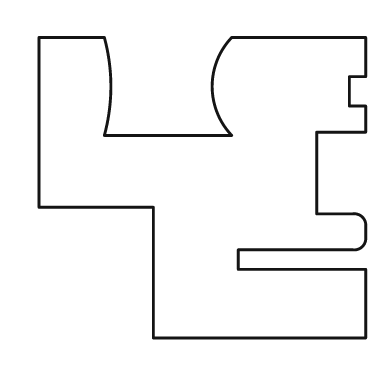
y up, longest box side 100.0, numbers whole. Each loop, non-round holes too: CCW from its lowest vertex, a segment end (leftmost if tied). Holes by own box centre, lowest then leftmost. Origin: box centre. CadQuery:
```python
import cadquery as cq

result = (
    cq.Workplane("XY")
    .moveTo(-15.0, -46.0)
    .lineTo(50.0, -46.0)
    .lineTo(50.0, -25.0)
    .lineTo(11.0, -25.0)
    .lineTo(11.0, -19.0)
    .lineTo(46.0, -19.0)
    .threePointArc((49.0, -18.0), (50.0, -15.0))
    .lineTo(50.0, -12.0)
    .threePointArc((49.0, -9.0), (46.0, -8.0))
    .lineTo(35.0, -8.0)
    .lineTo(35.0, 17.0)
    .lineTo(50.0, 17.0)
    .lineTo(50.0, 25.0)
    .lineTo(45.0, 25.0)
    .lineTo(45.0, 34.0)
    .lineTo(50.0, 34.0)
    .lineTo(50.0, 46.0)
    .lineTo(9.0, 46.0)
    .threePointArc((3.0, 31.0), (9.0, 16.0))
    .lineTo(-30.0, 16.0)
    .threePointArc((-28.0, 31.0), (-30.0, 46.0))
    .lineTo(-50.0, 46.0)
    .lineTo(-50.0, -6.0)
    .lineTo(-15.0, -6.0)
    .close()
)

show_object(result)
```